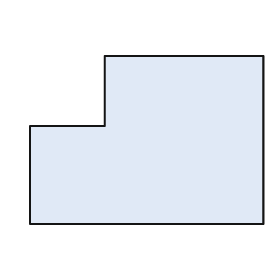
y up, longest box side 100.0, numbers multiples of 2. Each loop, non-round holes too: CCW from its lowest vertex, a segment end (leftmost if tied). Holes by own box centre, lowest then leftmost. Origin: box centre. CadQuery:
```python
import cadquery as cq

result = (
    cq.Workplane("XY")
    .moveTo(-50.0, -36.0)
    .lineTo(50.0, -36.0)
    .lineTo(50.0, 36.0)
    .lineTo(-18.0, 36.0)
    .lineTo(-18.0, 6.0)
    .lineTo(-50.0, 6.0)
    .close()
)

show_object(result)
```